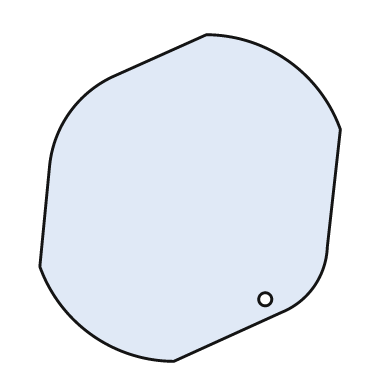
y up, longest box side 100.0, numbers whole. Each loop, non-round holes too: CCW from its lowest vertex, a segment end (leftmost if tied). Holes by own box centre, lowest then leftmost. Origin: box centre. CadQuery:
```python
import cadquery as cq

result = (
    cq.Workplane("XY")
    .moveTo(-5.0, -50.0)
    .lineTo(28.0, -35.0)
    .threePointArc((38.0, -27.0), (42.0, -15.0))
    .lineTo(46.0, 21.0)
    .threePointArc((30.0, 42.0), (5.0, 50.0))
    .lineTo(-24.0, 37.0)
    .threePointArc((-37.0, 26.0), (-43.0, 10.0))
    .lineTo(-46.0, -21.0)
    .threePointArc((-30.0, -42.0), (-5.0, -50.0))
    .close()
    .moveTo(23.0, -31.0)
    .circle(2.0)
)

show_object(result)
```